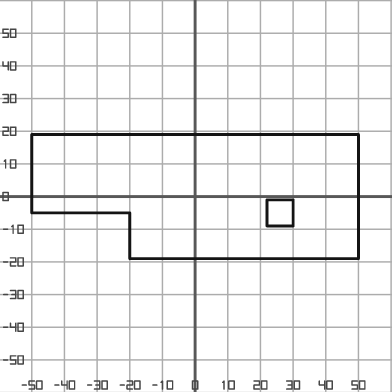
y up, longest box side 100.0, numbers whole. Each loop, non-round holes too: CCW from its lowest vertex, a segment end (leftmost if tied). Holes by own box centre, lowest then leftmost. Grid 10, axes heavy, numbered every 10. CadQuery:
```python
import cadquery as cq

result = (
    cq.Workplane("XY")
    .moveTo(-20.0, -19.0)
    .lineTo(50.0, -19.0)
    .lineTo(50.0, 19.0)
    .lineTo(-50.0, 19.0)
    .lineTo(-50.0, -5.0)
    .lineTo(-20.0, -5.0)
    .close()
    .moveTo(22.0, -9.0)
    .lineTo(30.0, -9.0)
    .lineTo(30.0, -1.0)
    .lineTo(22.0, -1.0)
    .close()
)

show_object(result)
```